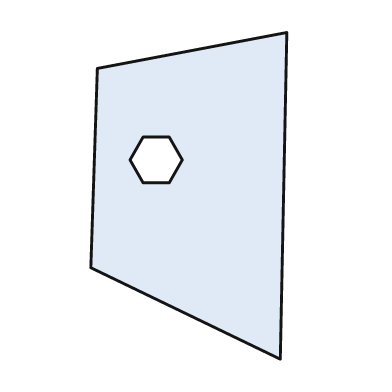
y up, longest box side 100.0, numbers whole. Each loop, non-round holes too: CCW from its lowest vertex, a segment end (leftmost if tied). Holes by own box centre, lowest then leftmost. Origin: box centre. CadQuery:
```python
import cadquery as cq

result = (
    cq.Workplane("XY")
    .moveTo(28.0, -50.0)
    .lineTo(30.0, 50.0)
    .lineTo(-28.0, 39.0)
    .lineTo(-30.0, -22.0)
    .close()
    .moveTo(-14.0, 4.0)
    .lineTo(-6.0, 4.0)
    .lineTo(-2.0, 11.0)
    .lineTo(-6.0, 18.0)
    .lineTo(-14.0, 18.0)
    .lineTo(-18.0, 11.0)
    .close()
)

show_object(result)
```